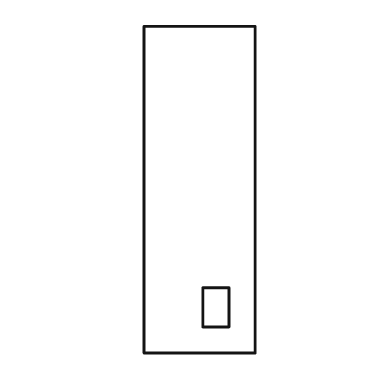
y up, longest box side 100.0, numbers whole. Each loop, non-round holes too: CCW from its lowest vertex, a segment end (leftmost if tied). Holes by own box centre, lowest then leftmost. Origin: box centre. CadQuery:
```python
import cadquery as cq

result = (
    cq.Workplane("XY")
    .moveTo(-17.0, -50.0)
    .lineTo(17.0, -50.0)
    .lineTo(17.0, 50.0)
    .lineTo(-17.0, 50.0)
    .close()
    .moveTo(1.0, -42.0)
    .lineTo(9.0, -42.0)
    .lineTo(9.0, -30.0)
    .lineTo(1.0, -30.0)
    .close()
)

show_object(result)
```